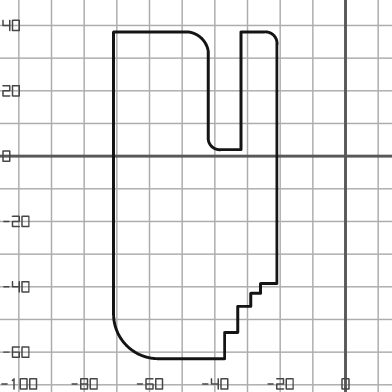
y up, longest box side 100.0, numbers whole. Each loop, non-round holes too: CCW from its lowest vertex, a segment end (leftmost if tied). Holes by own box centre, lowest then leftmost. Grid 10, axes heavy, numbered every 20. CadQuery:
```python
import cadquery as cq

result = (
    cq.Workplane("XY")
    .moveTo(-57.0, -62.0)
    .lineTo(-37.0, -62.0)
    .lineTo(-37.0, -54.0)
    .lineTo(-33.0, -54.0)
    .lineTo(-33.0, -46.0)
    .lineTo(-29.0, -46.0)
    .lineTo(-29.0, -42.0)
    .lineTo(-26.0, -42.0)
    .lineTo(-26.0, -39.0)
    .lineTo(-21.0, -39.0)
    .lineTo(-21.0, 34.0)
    .threePointArc((-22.0, 37.0), (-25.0, 38.0))
    .lineTo(-32.0, 38.0)
    .lineTo(-32.0, 2.0)
    .lineTo(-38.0, 2.0)
    .threePointArc((-41.0, 3.0), (-42.0, 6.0))
    .lineTo(-42.0, 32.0)
    .threePointArc((-44.0, 36.0), (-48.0, 38.0))
    .lineTo(-71.0, 38.0)
    .lineTo(-71.0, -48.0)
    .threePointArc((-67.0, -58.0), (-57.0, -62.0))
    .close()
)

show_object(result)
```